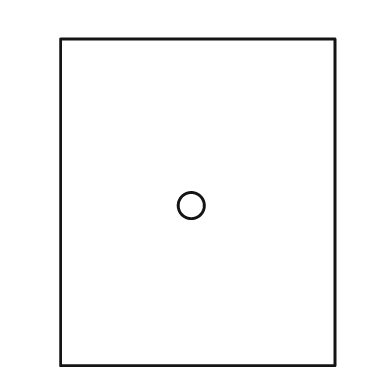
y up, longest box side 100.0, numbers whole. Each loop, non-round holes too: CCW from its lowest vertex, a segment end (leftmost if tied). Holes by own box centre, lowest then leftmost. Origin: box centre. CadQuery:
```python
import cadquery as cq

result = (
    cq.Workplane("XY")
    .moveTo(-42.0, -50.0)
    .lineTo(42.0, -50.0)
    .lineTo(42.0, 50.0)
    .lineTo(-42.0, 50.0)
    .close()
    .moveTo(-2.0, -1.0)
    .circle(4.0)
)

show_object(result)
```